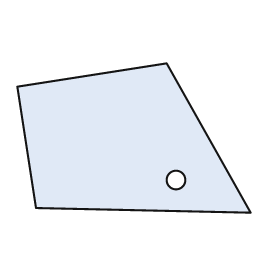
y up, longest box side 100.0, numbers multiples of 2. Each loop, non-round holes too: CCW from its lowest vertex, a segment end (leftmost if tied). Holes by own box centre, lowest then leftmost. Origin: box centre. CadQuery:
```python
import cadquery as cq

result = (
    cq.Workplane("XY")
    .moveTo(50.0, -32.0)
    .lineTo(14.0, 32.0)
    .lineTo(-50.0, 22.0)
    .lineTo(-42.0, -30.0)
    .close()
    .moveTo(18.0, -18.0)
    .circle(4.0)
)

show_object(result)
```